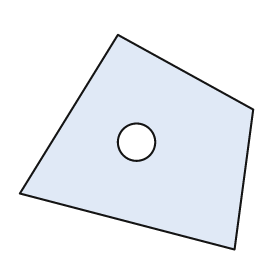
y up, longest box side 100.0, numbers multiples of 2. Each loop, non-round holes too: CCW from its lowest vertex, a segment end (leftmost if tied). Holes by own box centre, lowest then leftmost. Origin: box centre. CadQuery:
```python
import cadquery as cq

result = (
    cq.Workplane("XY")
    .moveTo(42.0, -46.0)
    .lineTo(50.0, 14.0)
    .lineTo(-8.0, 46.0)
    .lineTo(-50.0, -22.0)
    .close()
    .moveTo(0.0, 0.0)
    .circle(8.0)
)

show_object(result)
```